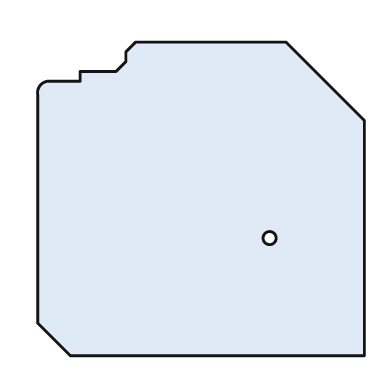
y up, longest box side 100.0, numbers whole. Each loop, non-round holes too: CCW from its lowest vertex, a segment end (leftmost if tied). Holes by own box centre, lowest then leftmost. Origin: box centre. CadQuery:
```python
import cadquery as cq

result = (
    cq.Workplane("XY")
    .moveTo(-40.0, -48.0)
    .lineTo(50.0, -48.0)
    .lineTo(50.0, 24.0)
    .lineTo(26.0, 48.0)
    .lineTo(-20.0, 48.0)
    .lineTo(-23.0, 45.0)
    .lineTo(-23.0, 42.0)
    .lineTo(-26.0, 39.0)
    .lineTo(-37.0, 39.0)
    .lineTo(-37.0, 36.0)
    .lineTo(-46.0, 36.0)
    .threePointArc((-49.0, 35.0), (-50.0, 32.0))
    .lineTo(-50.0, -38.0)
    .close()
    .moveTo(21.0, -12.0)
    .circle(2.0)
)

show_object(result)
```